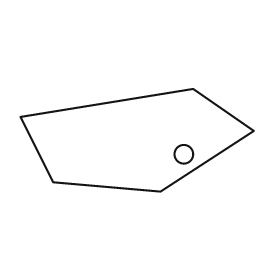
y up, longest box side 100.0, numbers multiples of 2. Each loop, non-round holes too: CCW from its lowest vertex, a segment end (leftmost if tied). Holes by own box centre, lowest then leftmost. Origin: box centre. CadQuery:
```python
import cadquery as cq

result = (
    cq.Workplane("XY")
    .moveTo(10.0, -22.0)
    .lineTo(50.0, 4.0)
    .lineTo(24.0, 22.0)
    .lineTo(-50.0, 10.0)
    .lineTo(-36.0, -18.0)
    .close()
    .moveTo(20.0, -6.0)
    .circle(4.0)
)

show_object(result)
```